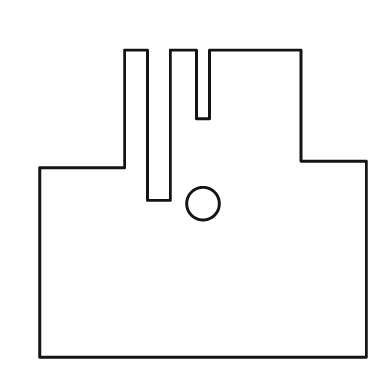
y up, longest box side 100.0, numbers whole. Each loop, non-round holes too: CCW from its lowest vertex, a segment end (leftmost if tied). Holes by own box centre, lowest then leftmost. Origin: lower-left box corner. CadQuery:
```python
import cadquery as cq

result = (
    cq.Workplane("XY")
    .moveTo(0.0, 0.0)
    .lineTo(100.0, 0.0)
    .lineTo(100.0, 60.0)
    .lineTo(80.0, 60.0)
    .lineTo(80.0, 94.0)
    .lineTo(52.0, 94.0)
    .lineTo(52.0, 73.0)
    .lineTo(48.0, 73.0)
    .lineTo(48.0, 94.0)
    .lineTo(40.0, 94.0)
    .lineTo(40.0, 48.0)
    .lineTo(33.0, 48.0)
    .lineTo(33.0, 94.0)
    .lineTo(26.0, 94.0)
    .lineTo(26.0, 58.0)
    .lineTo(0.0, 58.0)
    .close()
    .moveTo(50.0, 47.0)
    .circle(5.0)
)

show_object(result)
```